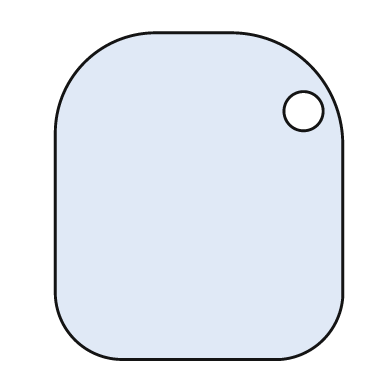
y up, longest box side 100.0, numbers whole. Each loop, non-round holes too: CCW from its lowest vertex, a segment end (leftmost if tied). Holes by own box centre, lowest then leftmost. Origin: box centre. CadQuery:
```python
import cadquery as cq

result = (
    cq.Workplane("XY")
    .moveTo(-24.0, -50.0)
    .lineTo(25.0, -50.0)
    .threePointArc((38.0, -44.0), (44.0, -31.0))
    .lineTo(44.0, 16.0)
    .threePointArc((34.0, 40.0), (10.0, 50.0))
    .lineTo(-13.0, 50.0)
    .threePointArc((-35.0, 41.0), (-44.0, 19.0))
    .lineTo(-44.0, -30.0)
    .threePointArc((-38.0, -44.0), (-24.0, -50.0))
    .close()
    .moveTo(32.0, 26.0)
    .circle(6.0)
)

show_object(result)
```